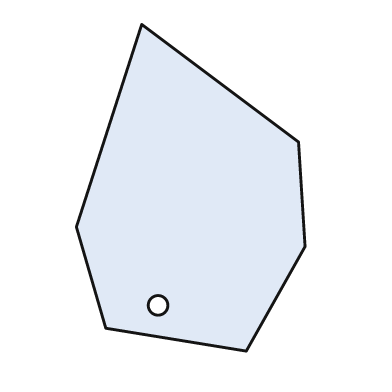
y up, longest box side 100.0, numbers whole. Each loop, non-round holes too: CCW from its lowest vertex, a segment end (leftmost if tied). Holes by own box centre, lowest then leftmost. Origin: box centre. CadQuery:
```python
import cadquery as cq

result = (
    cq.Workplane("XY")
    .moveTo(17.0, -50.0)
    .lineTo(35.0, -18.0)
    .lineTo(33.0, 14.0)
    .lineTo(-15.0, 50.0)
    .lineTo(-35.0, -12.0)
    .lineTo(-26.0, -43.0)
    .close()
    .moveTo(-10.0, -36.0)
    .circle(3.0)
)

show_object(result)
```